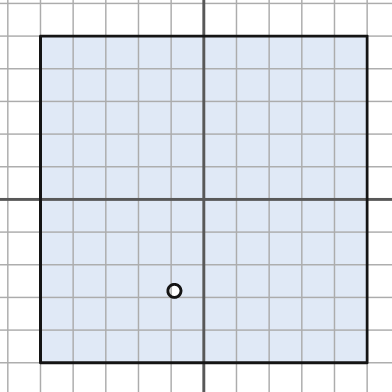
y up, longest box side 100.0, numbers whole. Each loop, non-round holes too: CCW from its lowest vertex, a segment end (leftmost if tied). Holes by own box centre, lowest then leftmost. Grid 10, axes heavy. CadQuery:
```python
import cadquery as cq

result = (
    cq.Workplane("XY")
    .moveTo(-50.0, -50.0)
    .lineTo(50.0, -50.0)
    .lineTo(50.0, 50.0)
    .lineTo(-50.0, 50.0)
    .close()
    .moveTo(-9.0, -28.0)
    .circle(2.0)
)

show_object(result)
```